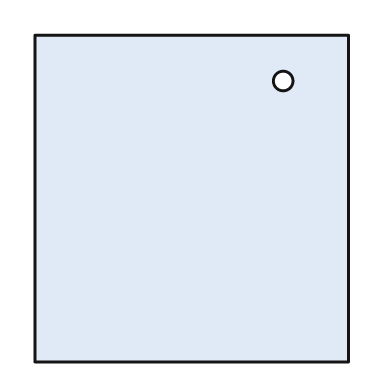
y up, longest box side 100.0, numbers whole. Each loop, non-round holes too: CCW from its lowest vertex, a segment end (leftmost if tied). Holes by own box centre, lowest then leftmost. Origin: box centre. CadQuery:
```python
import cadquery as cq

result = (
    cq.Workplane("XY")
    .moveTo(-48.0, -50.0)
    .lineTo(48.0, -50.0)
    .lineTo(48.0, 50.0)
    .lineTo(-48.0, 50.0)
    .close()
    .moveTo(28.0, 36.0)
    .circle(3.0)
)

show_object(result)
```